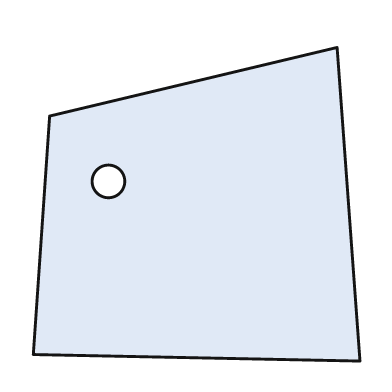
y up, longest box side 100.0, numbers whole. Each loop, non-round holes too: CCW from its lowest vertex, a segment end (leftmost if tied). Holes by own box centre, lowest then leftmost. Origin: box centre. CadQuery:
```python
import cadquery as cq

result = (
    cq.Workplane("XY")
    .moveTo(50.0, -48.0)
    .lineTo(43.0, 48.0)
    .lineTo(-45.0, 27.0)
    .lineTo(-50.0, -46.0)
    .close()
    .moveTo(-27.0, 7.0)
    .circle(5.0)
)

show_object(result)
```